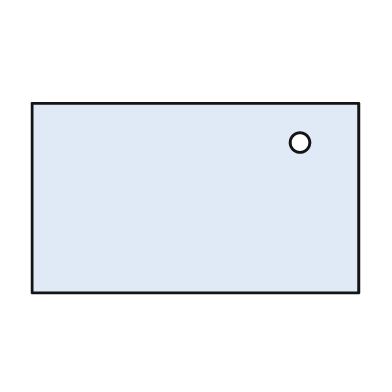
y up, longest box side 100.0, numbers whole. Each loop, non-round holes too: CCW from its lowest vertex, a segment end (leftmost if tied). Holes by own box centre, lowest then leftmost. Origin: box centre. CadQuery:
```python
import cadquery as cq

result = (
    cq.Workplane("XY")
    .moveTo(-50.0, -29.0)
    .lineTo(50.0, -29.0)
    .lineTo(50.0, 29.0)
    .lineTo(-50.0, 29.0)
    .close()
    .moveTo(32.0, 17.0)
    .circle(3.0)
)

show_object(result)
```